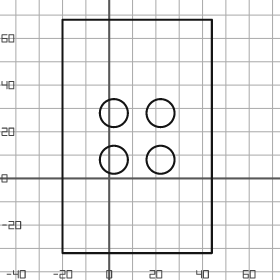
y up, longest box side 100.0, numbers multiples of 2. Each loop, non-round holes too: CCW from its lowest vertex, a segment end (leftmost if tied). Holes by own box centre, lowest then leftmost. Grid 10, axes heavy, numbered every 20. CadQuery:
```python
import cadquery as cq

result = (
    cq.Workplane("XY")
    .moveTo(-20.0, -32.0)
    .lineTo(44.0, -32.0)
    .lineTo(44.0, 68.0)
    .lineTo(-20.0, 68.0)
    .close()
    .moveTo(2.0, 8.0)
    .circle(6.0)
    .moveTo(22.0, 8.0)
    .circle(6.0)
    .moveTo(2.0, 28.0)
    .circle(6.0)
    .moveTo(22.0, 28.0)
    .circle(6.0)
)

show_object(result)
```